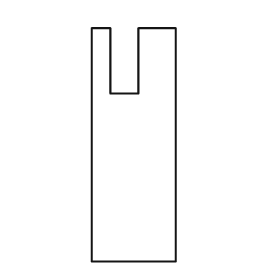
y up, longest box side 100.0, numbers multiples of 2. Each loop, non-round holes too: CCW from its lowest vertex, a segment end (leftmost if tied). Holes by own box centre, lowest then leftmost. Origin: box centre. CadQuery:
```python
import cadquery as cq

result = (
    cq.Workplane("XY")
    .moveTo(-18.0, -50.0)
    .lineTo(18.0, -50.0)
    .lineTo(18.0, 50.0)
    .lineTo(2.0, 50.0)
    .lineTo(2.0, 22.0)
    .lineTo(-10.0, 22.0)
    .lineTo(-10.0, 50.0)
    .lineTo(-18.0, 50.0)
    .close()
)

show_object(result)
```